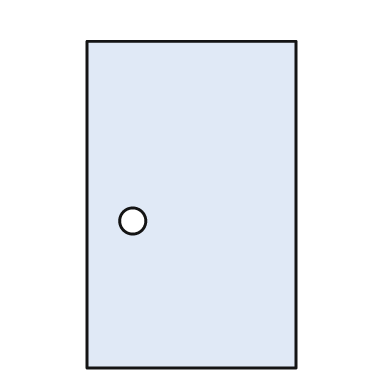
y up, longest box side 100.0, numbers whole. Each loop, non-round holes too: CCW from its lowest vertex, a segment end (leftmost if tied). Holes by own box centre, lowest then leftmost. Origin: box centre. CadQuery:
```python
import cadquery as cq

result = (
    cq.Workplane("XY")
    .moveTo(-32.0, -50.0)
    .lineTo(32.0, -50.0)
    .lineTo(32.0, 50.0)
    .lineTo(-32.0, 50.0)
    .close()
    .moveTo(-18.0, -5.0)
    .circle(4.0)
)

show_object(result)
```